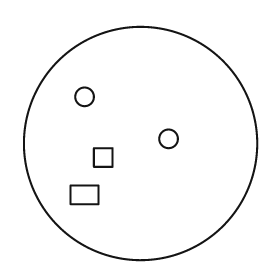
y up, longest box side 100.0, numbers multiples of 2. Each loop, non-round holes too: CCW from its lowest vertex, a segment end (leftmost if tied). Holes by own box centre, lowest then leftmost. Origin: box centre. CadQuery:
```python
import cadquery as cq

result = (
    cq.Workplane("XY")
    .moveTo(0.0, 0.0)
    .circle(50.0)
    .moveTo(-30.0, -26.0)
    .lineTo(-18.0, -26.0)
    .lineTo(-18.0, -18.0)
    .lineTo(-30.0, -18.0)
    .close()
    .moveTo(-20.0, -10.0)
    .lineTo(-12.0, -10.0)
    .lineTo(-12.0, -2.0)
    .lineTo(-20.0, -2.0)
    .close()
    .moveTo(12.0, 2.0)
    .circle(4.0)
    .moveTo(-24.0, 20.0)
    .circle(4.0)
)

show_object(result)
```